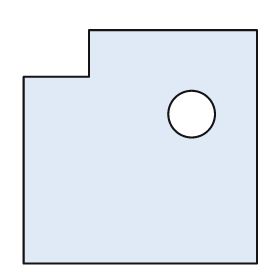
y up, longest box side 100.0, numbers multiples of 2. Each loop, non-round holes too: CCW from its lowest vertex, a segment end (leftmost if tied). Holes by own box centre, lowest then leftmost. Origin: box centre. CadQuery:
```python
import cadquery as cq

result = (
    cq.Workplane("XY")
    .moveTo(-50.0, -50.0)
    .lineTo(50.0, -50.0)
    .lineTo(50.0, 50.0)
    .lineTo(-22.0, 50.0)
    .lineTo(-22.0, 30.0)
    .lineTo(-50.0, 30.0)
    .close()
    .moveTo(22.0, 14.0)
    .circle(10.0)
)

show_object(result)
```